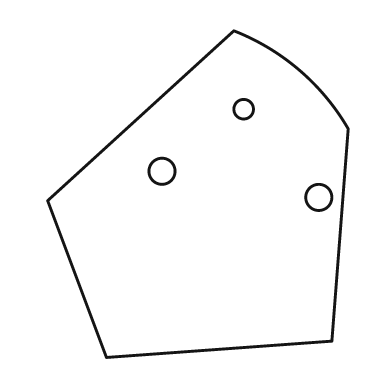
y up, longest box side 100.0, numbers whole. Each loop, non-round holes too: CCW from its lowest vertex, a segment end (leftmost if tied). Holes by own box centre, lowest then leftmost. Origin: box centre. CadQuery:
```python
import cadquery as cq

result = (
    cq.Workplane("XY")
    .moveTo(-28.0, -50.0)
    .lineTo(41.0, -45.0)
    .lineTo(46.0, 20.0)
    .threePointArc((31.0, 38.0), (11.0, 50.0))
    .lineTo(-46.0, -2.0)
    .close()
    .moveTo(37.0, -1.0)
    .circle(4.0)
    .moveTo(-11.0, 7.0)
    .circle(4.0)
    .moveTo(14.0, 26.0)
    .circle(3.0)
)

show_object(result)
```